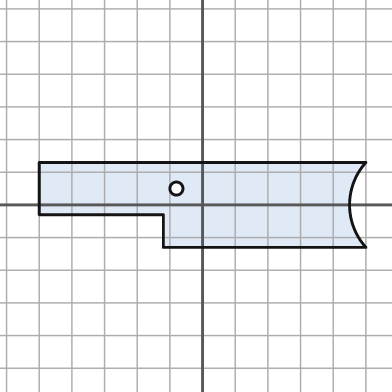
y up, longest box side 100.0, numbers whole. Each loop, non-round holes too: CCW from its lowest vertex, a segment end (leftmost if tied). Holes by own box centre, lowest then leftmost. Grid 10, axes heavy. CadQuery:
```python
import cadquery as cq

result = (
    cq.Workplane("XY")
    .moveTo(-12.0, -13.0)
    .lineTo(50.0, -13.0)
    .threePointArc((45.0, 0.0), (50.0, 13.0))
    .lineTo(-50.0, 13.0)
    .lineTo(-50.0, -3.0)
    .lineTo(-12.0, -3.0)
    .close()
    .moveTo(-8.0, 5.0)
    .circle(2.0)
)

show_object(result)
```